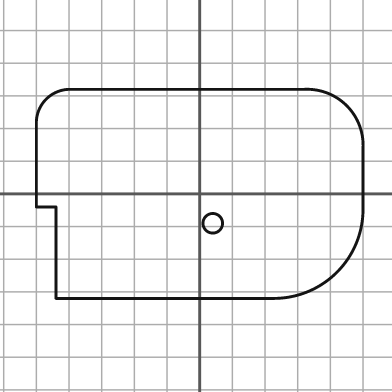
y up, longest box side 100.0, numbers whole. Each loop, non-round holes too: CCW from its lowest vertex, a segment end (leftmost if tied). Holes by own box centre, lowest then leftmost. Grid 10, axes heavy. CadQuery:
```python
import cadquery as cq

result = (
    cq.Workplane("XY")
    .moveTo(-44.0, -32.0)
    .lineTo(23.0, -32.0)
    .threePointArc((42.0, -24.0), (50.0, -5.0))
    .lineTo(50.0, 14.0)
    .threePointArc((45.0, 27.0), (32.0, 32.0))
    .lineTo(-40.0, 32.0)
    .threePointArc((-47.0, 29.0), (-50.0, 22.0))
    .lineTo(-50.0, -4.0)
    .lineTo(-44.0, -4.0)
    .close()
    .moveTo(4.0, -9.0)
    .circle(3.0)
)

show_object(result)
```